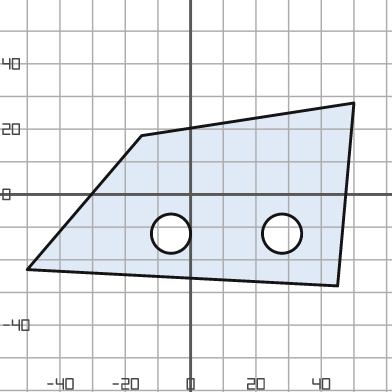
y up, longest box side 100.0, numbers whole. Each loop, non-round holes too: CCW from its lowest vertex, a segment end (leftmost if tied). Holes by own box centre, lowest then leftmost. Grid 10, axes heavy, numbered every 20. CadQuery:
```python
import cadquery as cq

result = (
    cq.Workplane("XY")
    .moveTo(45.0, -28.0)
    .lineTo(50.0, 28.0)
    .lineTo(-15.0, 18.0)
    .lineTo(-50.0, -23.0)
    .close()
    .moveTo(-6.0, -12.0)
    .circle(6.0)
    .moveTo(28.0, -12.0)
    .circle(6.0)
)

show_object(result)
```